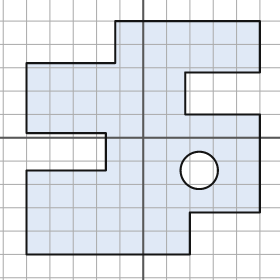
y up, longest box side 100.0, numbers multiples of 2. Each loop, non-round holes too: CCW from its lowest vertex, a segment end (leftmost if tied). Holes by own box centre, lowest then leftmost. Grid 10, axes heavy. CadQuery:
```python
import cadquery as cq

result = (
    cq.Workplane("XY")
    .moveTo(-50.0, -50.0)
    .lineTo(20.0, -50.0)
    .lineTo(20.0, -32.0)
    .lineTo(50.0, -32.0)
    .lineTo(50.0, 10.0)
    .lineTo(18.0, 10.0)
    .lineTo(18.0, 28.0)
    .lineTo(50.0, 28.0)
    .lineTo(50.0, 50.0)
    .lineTo(-12.0, 50.0)
    .lineTo(-12.0, 32.0)
    .lineTo(-50.0, 32.0)
    .lineTo(-50.0, 2.0)
    .lineTo(-16.0, 2.0)
    .lineTo(-16.0, -14.0)
    .lineTo(-50.0, -14.0)
    .close()
    .moveTo(24.0, -14.0)
    .circle(8.0)
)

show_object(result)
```